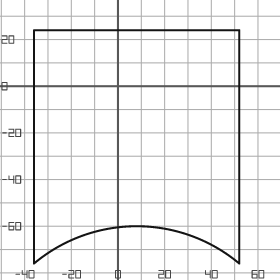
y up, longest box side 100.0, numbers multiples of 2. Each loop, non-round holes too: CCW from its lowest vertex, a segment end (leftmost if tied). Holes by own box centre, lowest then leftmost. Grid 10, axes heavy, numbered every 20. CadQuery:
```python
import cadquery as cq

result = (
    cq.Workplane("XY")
    .moveTo(-36.0, -76.0)
    .threePointArc((8.0, -60.0), (52.0, -76.0))
    .lineTo(52.0, 24.0)
    .lineTo(-36.0, 24.0)
    .close()
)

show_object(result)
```